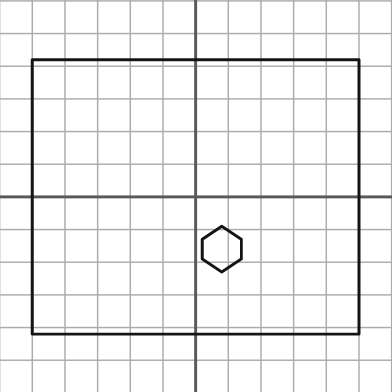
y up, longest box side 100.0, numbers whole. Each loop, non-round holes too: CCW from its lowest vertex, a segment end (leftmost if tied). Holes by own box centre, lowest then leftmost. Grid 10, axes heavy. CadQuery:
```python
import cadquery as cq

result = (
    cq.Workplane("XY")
    .moveTo(-50.0, -42.0)
    .lineTo(50.0, -42.0)
    .lineTo(50.0, 42.0)
    .lineTo(-50.0, 42.0)
    .close()
    .moveTo(8.0, -23.0)
    .lineTo(14.0, -19.0)
    .lineTo(14.0, -13.0)
    .lineTo(8.0, -9.0)
    .lineTo(2.0, -13.0)
    .lineTo(2.0, -19.0)
    .close()
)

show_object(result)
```